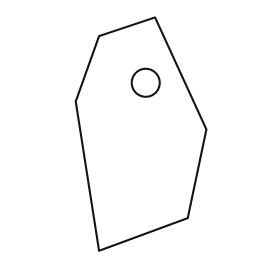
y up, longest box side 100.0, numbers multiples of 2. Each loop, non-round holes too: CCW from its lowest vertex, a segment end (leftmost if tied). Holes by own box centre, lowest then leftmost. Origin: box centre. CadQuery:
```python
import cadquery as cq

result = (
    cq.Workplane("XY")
    .moveTo(-18.0, -50.0)
    .lineTo(20.0, -36.0)
    .lineTo(28.0, 2.0)
    .lineTo(6.0, 50.0)
    .lineTo(-18.0, 42.0)
    .lineTo(-28.0, 14.0)
    .close()
    .moveTo(2.0, 22.0)
    .circle(6.0)
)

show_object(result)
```